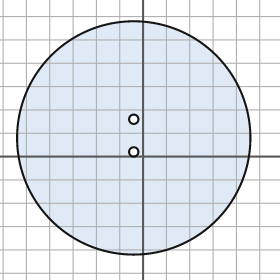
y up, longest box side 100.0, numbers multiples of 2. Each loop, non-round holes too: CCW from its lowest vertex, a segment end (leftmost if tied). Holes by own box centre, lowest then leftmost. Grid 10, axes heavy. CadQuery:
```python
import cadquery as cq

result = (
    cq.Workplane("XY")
    .moveTo(-4.0, 8.0)
    .circle(50.0)
    .moveTo(-4.0, 2.0)
    .circle(2.0)
    .moveTo(-4.0, 16.0)
    .circle(2.0)
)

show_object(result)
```